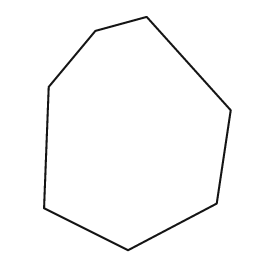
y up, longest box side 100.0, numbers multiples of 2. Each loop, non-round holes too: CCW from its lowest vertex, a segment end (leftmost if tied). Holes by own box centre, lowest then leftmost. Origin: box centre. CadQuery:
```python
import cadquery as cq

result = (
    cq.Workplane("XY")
    .moveTo(-4.0, -50.0)
    .lineTo(34.0, -30.0)
    .lineTo(40.0, 10.0)
    .lineTo(4.0, 50.0)
    .lineTo(-18.0, 44.0)
    .lineTo(-38.0, 20.0)
    .lineTo(-40.0, -32.0)
    .close()
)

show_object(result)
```